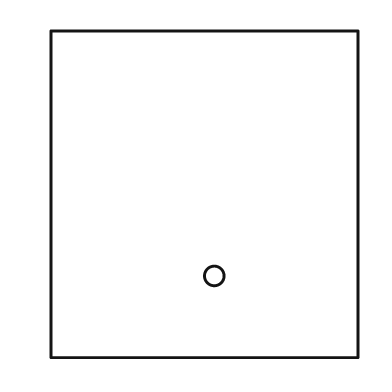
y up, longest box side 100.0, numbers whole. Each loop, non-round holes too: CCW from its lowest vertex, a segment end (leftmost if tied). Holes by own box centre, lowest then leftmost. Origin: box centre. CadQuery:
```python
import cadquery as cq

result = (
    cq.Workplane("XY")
    .moveTo(-47.0, -50.0)
    .lineTo(47.0, -50.0)
    .lineTo(47.0, 50.0)
    .lineTo(-47.0, 50.0)
    .close()
    .moveTo(3.0, -25.0)
    .circle(3.0)
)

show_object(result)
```